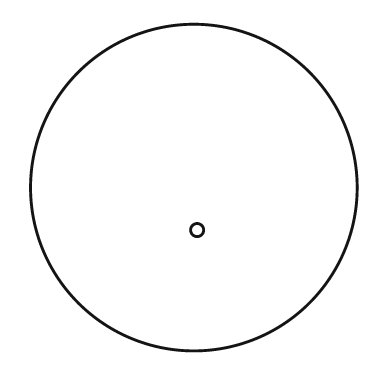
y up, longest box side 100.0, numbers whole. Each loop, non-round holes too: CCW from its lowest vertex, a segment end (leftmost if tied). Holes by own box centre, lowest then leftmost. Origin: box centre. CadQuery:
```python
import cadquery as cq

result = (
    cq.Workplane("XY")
    .moveTo(0.0, 0.0)
    .circle(50.0)
    .moveTo(1.0, -13.0)
    .circle(2.0)
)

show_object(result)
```